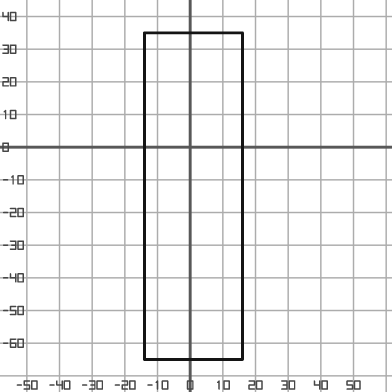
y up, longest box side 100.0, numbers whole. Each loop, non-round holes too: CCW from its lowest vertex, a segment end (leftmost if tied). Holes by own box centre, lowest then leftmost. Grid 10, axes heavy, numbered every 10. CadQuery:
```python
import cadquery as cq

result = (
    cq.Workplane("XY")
    .moveTo(-14.0, -65.0)
    .lineTo(16.0, -65.0)
    .lineTo(16.0, 35.0)
    .lineTo(-14.0, 35.0)
    .close()
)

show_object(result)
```